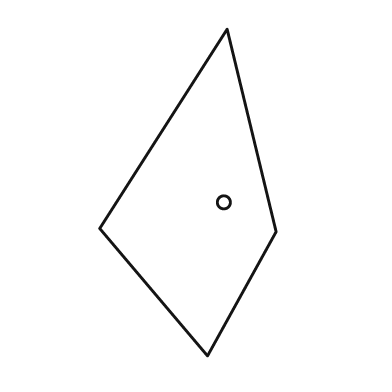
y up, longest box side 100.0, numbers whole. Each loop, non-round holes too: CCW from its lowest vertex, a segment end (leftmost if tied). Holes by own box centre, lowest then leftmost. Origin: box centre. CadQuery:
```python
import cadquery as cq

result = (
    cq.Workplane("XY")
    .moveTo(6.0, -50.0)
    .lineTo(27.0, -12.0)
    .lineTo(12.0, 50.0)
    .lineTo(-27.0, -11.0)
    .close()
    .moveTo(11.0, -3.0)
    .circle(2.0)
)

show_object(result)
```